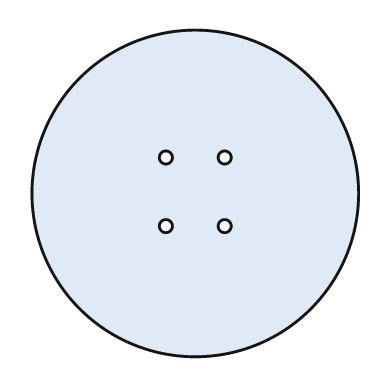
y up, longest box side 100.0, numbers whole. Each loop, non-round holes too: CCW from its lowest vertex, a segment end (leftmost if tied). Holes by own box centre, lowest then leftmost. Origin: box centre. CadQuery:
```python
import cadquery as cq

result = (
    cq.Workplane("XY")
    .moveTo(0.0, 0.0)
    .circle(50.0)
    .moveTo(-9.0, -10.0)
    .circle(2.0)
    .moveTo(9.0, -10.0)
    .circle(2.0)
    .moveTo(-9.0, 11.0)
    .circle(2.0)
    .moveTo(9.0, 11.0)
    .circle(2.0)
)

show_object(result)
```